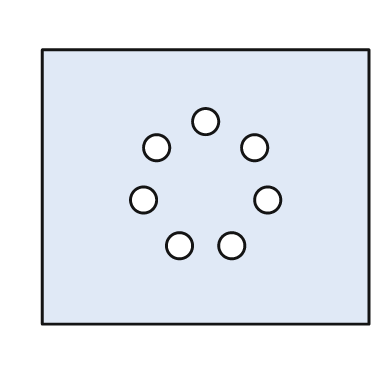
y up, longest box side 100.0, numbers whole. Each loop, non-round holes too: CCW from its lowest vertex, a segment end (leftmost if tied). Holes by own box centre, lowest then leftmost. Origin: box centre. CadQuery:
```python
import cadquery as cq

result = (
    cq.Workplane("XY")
    .moveTo(-50.0, -42.0)
    .lineTo(50.0, -42.0)
    .lineTo(50.0, 42.0)
    .lineTo(-50.0, 42.0)
    .close()
    .moveTo(-8.0, -18.0)
    .circle(4.0)
    .moveTo(8.0, -18.0)
    .circle(4.0)
    .moveTo(-19.0, -4.0)
    .circle(4.0)
    .moveTo(19.0, -4.0)
    .circle(4.0)
    .moveTo(-15.0, 12.0)
    .circle(4.0)
    .moveTo(15.0, 12.0)
    .circle(4.0)
    .moveTo(0.0, 20.0)
    .circle(4.0)
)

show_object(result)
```